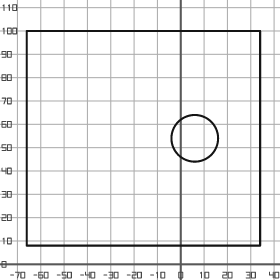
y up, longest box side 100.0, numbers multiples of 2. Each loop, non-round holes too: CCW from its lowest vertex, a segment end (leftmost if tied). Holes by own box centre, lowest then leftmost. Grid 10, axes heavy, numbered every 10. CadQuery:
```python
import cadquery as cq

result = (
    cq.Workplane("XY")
    .moveTo(-66.0, 8.0)
    .lineTo(34.0, 8.0)
    .lineTo(34.0, 100.0)
    .lineTo(-66.0, 100.0)
    .close()
    .moveTo(6.0, 54.0)
    .circle(10.0)
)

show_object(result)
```